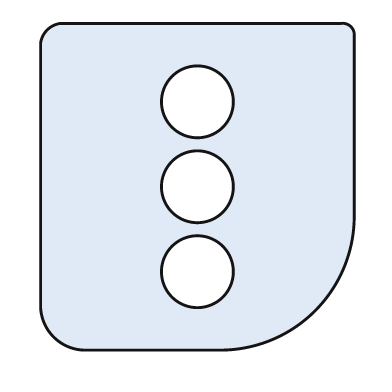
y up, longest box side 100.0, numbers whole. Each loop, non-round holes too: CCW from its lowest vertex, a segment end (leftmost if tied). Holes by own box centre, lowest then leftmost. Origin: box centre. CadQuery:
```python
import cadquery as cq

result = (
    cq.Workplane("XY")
    .moveTo(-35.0, -50.0)
    .lineTo(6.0, -50.0)
    .threePointArc((36.0, -38.0), (48.0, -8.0))
    .lineTo(48.0, 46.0)
    .threePointArc((47.0, 49.0), (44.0, 50.0))
    .lineTo(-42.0, 50.0)
    .threePointArc((-46.0, 48.0), (-48.0, 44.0))
    .lineTo(-48.0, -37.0)
    .threePointArc((-44.0, -46.0), (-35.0, -50.0))
    .close()
    .moveTo(0.0, -26.0)
    .circle(11.0)
    .moveTo(0.0, 0.0)
    .circle(11.0)
    .moveTo(0.0, 26.0)
    .circle(11.0)
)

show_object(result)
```